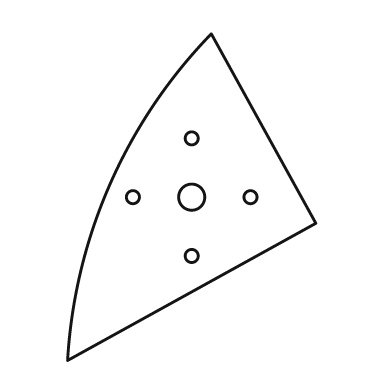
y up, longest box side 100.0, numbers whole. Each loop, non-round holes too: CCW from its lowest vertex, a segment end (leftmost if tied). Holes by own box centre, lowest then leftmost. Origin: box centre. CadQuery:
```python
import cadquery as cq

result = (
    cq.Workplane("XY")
    .moveTo(-38.0, -50.0)
    .lineTo(38.0, -8.0)
    .lineTo(6.0, 50.0)
    .threePointArc((-25.0, 4.0), (-38.0, -50.0))
    .close()
    .moveTo(0.0, -18.0)
    .circle(2.0)
    .moveTo(-18.0, 0.0)
    .circle(2.0)
    .moveTo(0.0, 0.0)
    .circle(4.0)
    .moveTo(18.0, 0.0)
    .circle(2.0)
    .moveTo(0.0, 18.0)
    .circle(2.0)
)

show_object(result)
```